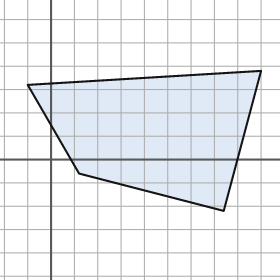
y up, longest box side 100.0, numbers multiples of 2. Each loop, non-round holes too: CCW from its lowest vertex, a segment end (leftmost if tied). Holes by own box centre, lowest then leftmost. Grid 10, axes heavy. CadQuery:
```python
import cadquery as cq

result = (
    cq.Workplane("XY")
    .moveTo(74.0, -22.0)
    .lineTo(90.0, 38.0)
    .lineTo(-10.0, 32.0)
    .lineTo(12.0, -6.0)
    .close()
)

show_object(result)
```